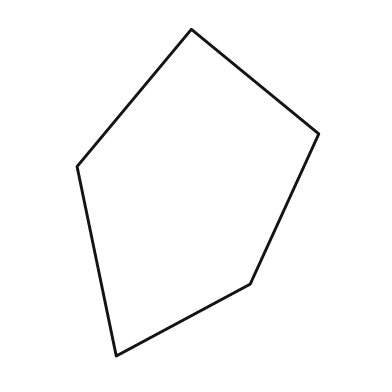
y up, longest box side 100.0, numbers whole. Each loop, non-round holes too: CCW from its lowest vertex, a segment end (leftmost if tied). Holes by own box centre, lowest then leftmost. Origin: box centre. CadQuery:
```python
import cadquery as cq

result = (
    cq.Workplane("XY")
    .moveTo(-25.0, -50.0)
    .lineTo(16.0, -28.0)
    .lineTo(37.0, 18.0)
    .lineTo(-2.0, 50.0)
    .lineTo(-37.0, 8.0)
    .close()
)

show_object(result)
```